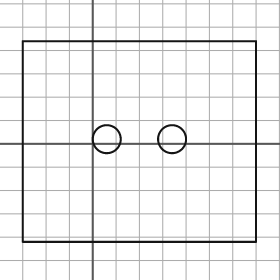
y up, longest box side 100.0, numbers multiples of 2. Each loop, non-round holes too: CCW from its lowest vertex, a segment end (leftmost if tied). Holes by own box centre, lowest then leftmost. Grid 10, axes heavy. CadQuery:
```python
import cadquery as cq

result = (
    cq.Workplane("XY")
    .moveTo(-30.0, -42.0)
    .lineTo(70.0, -42.0)
    .lineTo(70.0, 44.0)
    .lineTo(-30.0, 44.0)
    .close()
    .moveTo(6.0, 2.0)
    .circle(6.0)
    .moveTo(34.0, 2.0)
    .circle(6.0)
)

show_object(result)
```